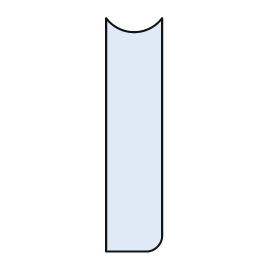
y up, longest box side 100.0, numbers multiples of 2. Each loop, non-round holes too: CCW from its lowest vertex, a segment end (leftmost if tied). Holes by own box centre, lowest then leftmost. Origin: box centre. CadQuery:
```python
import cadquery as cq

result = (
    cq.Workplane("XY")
    .moveTo(-12.0, -50.0)
    .lineTo(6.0, -50.0)
    .threePointArc((10.0, -48.0), (12.0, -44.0))
    .lineTo(12.0, 50.0)
    .threePointArc((0.0, 44.0), (-12.0, 50.0))
    .close()
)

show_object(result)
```